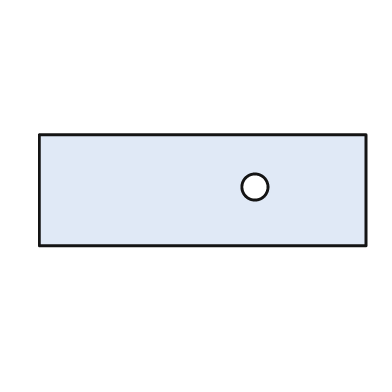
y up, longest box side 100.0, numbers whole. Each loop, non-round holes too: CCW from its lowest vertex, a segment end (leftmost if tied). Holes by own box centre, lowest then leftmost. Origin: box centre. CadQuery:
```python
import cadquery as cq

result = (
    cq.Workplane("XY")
    .moveTo(-50.0, -17.0)
    .lineTo(50.0, -17.0)
    .lineTo(50.0, 17.0)
    .lineTo(-50.0, 17.0)
    .close()
    .moveTo(16.0, 1.0)
    .circle(4.0)
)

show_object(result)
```